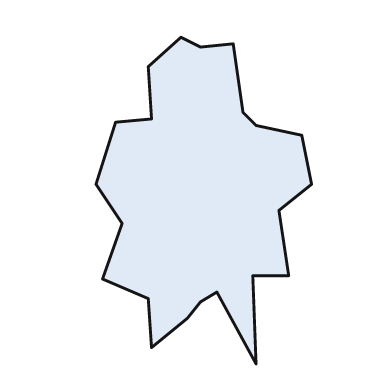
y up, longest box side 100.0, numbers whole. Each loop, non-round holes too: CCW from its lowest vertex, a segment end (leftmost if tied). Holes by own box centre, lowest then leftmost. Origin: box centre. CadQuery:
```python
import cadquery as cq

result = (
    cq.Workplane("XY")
    .moveTo(16.0, -50.0)
    .lineTo(15.0, -23.0)
    .lineTo(26.0, -23.0)
    .lineTo(23.0, -3.0)
    .lineTo(33.0, 5.0)
    .lineTo(30.0, 20.0)
    .lineTo(16.0, 23.0)
    .lineTo(12.0, 27.0)
    .lineTo(9.0, 48.0)
    .lineTo(-1.0, 47.0)
    .lineTo(-7.0, 50.0)
    .lineTo(-17.0, 41.0)
    .lineTo(-16.0, 25.0)
    .lineTo(-27.0, 24.0)
    .lineTo(-33.0, 5.0)
    .lineTo(-25.0, -7.0)
    .lineTo(-31.0, -24.0)
    .lineTo(-17.0, -30.0)
    .lineTo(-16.0, -45.0)
    .lineTo(-5.0, -36.0)
    .lineTo(-1.0, -31.0)
    .lineTo(4.0, -28.0)
    .close()
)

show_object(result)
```